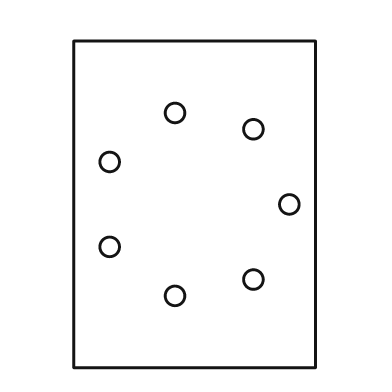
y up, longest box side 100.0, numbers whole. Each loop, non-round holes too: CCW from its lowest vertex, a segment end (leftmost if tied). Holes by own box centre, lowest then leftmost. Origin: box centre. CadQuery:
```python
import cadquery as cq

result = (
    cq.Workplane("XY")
    .moveTo(-37.0, -50.0)
    .lineTo(37.0, -50.0)
    .lineTo(37.0, 50.0)
    .lineTo(-37.0, 50.0)
    .close()
    .moveTo(-6.0, -28.0)
    .circle(3.0)
    .moveTo(18.0, -23.0)
    .circle(3.0)
    .moveTo(-26.0, -13.0)
    .circle(3.0)
    .moveTo(29.0, 0.0)
    .circle(3.0)
    .moveTo(-26.0, 13.0)
    .circle(3.0)
    .moveTo(18.0, 23.0)
    .circle(3.0)
    .moveTo(-6.0, 28.0)
    .circle(3.0)
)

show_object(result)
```